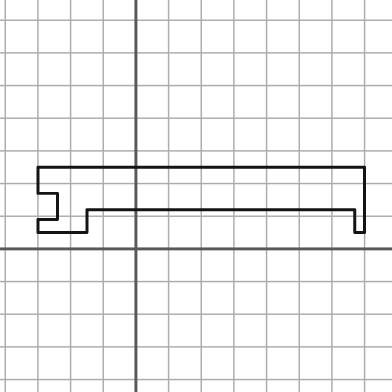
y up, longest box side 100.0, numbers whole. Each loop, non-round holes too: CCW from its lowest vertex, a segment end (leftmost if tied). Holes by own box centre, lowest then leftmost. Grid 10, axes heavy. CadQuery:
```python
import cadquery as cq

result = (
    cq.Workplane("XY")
    .moveTo(-30.0, 5.0)
    .lineTo(-15.0, 5.0)
    .lineTo(-15.0, 12.0)
    .lineTo(67.0, 12.0)
    .lineTo(67.0, 5.0)
    .lineTo(70.0, 5.0)
    .lineTo(70.0, 25.0)
    .lineTo(-30.0, 25.0)
    .lineTo(-30.0, 17.0)
    .lineTo(-24.0, 17.0)
    .lineTo(-24.0, 9.0)
    .lineTo(-30.0, 9.0)
    .close()
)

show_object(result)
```